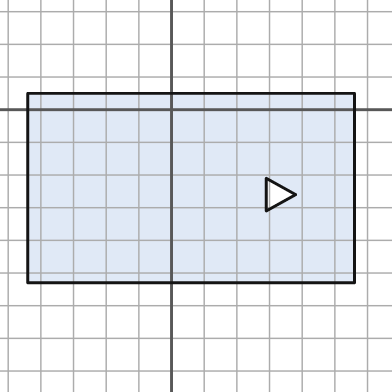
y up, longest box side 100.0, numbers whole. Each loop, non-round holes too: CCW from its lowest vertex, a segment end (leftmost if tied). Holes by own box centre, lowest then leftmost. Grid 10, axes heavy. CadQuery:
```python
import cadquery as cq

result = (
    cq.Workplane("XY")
    .moveTo(-44.0, -53.0)
    .lineTo(56.0, -53.0)
    .lineTo(56.0, 5.0)
    .lineTo(-44.0, 5.0)
    .close()
    .moveTo(29.0, -31.0)
    .lineTo(38.0, -26.0)
    .lineTo(29.0, -21.0)
    .close()
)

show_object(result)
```